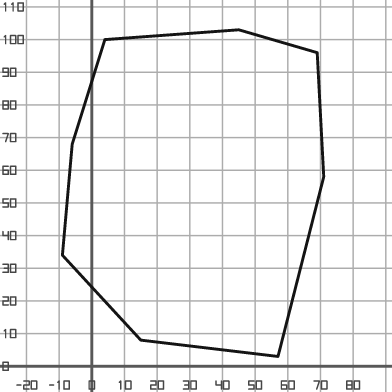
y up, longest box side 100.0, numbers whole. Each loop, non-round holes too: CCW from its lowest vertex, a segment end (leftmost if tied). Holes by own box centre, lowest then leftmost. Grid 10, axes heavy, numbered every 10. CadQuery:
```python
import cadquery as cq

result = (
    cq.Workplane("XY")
    .moveTo(57.0, 3.0)
    .lineTo(71.0, 58.0)
    .lineTo(69.0, 96.0)
    .lineTo(45.0, 103.0)
    .lineTo(4.0, 100.0)
    .lineTo(-6.0, 68.0)
    .lineTo(-9.0, 34.0)
    .lineTo(15.0, 8.0)
    .close()
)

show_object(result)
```